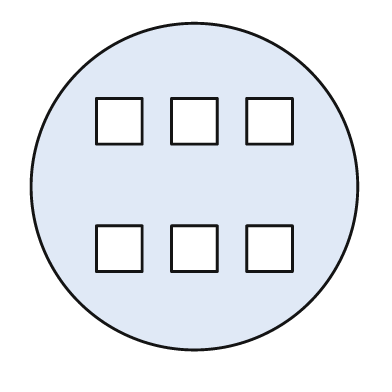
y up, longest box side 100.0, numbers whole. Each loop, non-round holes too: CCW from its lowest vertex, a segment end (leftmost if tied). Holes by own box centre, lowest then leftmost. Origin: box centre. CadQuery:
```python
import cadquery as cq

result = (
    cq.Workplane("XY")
    .moveTo(0.0, 0.0)
    .circle(50.0)
    .moveTo(-30.0, -26.0)
    .lineTo(-16.0, -26.0)
    .lineTo(-16.0, -12.0)
    .lineTo(-30.0, -12.0)
    .close()
    .moveTo(-7.0, -26.0)
    .lineTo(7.0, -26.0)
    .lineTo(7.0, -12.0)
    .lineTo(-7.0, -12.0)
    .close()
    .moveTo(16.0, -26.0)
    .lineTo(30.0, -26.0)
    .lineTo(30.0, -12.0)
    .lineTo(16.0, -12.0)
    .close()
    .moveTo(-30.0, 13.0)
    .lineTo(-16.0, 13.0)
    .lineTo(-16.0, 27.0)
    .lineTo(-30.0, 27.0)
    .close()
    .moveTo(-7.0, 13.0)
    .lineTo(7.0, 13.0)
    .lineTo(7.0, 27.0)
    .lineTo(-7.0, 27.0)
    .close()
    .moveTo(16.0, 13.0)
    .lineTo(30.0, 13.0)
    .lineTo(30.0, 27.0)
    .lineTo(16.0, 27.0)
    .close()
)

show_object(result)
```